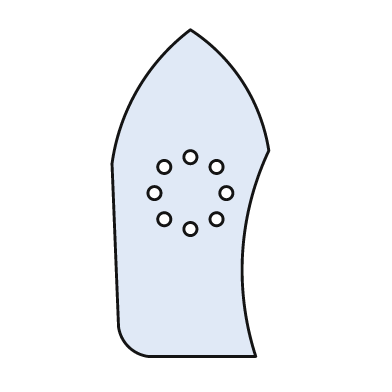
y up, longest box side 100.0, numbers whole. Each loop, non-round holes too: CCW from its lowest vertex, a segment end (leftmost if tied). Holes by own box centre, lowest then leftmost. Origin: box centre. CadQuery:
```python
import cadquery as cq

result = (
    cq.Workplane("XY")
    .moveTo(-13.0, -50.0)
    .lineTo(20.0, -50.0)
    .threePointArc((16.0, -18.0), (24.0, 13.0))
    .threePointArc((16.0, 34.0), (0.0, 50.0))
    .threePointArc((-16.0, 32.0), (-24.0, 9.0))
    .lineTo(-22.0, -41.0)
    .threePointArc((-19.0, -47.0), (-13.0, -50.0))
    .close()
    .moveTo(0.0, -11.0)
    .circle(2.0)
    .moveTo(-8.0, -8.0)
    .circle(2.0)
    .moveTo(8.0, -8.0)
    .circle(2.0)
    .moveTo(-11.0, 0.0)
    .circle(2.0)
    .moveTo(11.0, 0.0)
    .circle(2.0)
    .moveTo(-8.0, 8.0)
    .circle(2.0)
    .moveTo(8.0, 8.0)
    .circle(2.0)
    .moveTo(0.0, 11.0)
    .circle(2.0)
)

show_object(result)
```